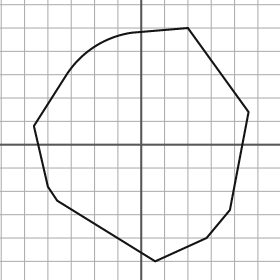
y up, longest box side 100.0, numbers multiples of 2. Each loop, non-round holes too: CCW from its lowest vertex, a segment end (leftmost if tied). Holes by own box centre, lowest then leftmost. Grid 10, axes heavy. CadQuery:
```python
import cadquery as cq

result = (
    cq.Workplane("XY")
    .moveTo(6.0, -50.0)
    .lineTo(28.0, -40.0)
    .lineTo(38.0, -28.0)
    .lineTo(46.0, 14.0)
    .lineTo(20.0, 50.0)
    .lineTo(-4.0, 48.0)
    .threePointArc((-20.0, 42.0), (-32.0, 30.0))
    .lineTo(-46.0, 8.0)
    .lineTo(-40.0, -18.0)
    .lineTo(-36.0, -24.0)
    .close()
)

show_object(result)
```